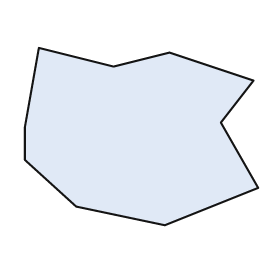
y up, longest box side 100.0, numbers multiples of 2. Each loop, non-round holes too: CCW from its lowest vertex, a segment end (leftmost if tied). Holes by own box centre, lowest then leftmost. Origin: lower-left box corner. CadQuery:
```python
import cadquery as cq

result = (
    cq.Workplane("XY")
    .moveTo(60.0, 0.0)
    .lineTo(100.0, 16.0)
    .lineTo(84.0, 44.0)
    .lineTo(98.0, 62.0)
    .lineTo(62.0, 74.0)
    .lineTo(38.0, 68.0)
    .lineTo(6.0, 76.0)
    .lineTo(0.0, 42.0)
    .lineTo(0.0, 28.0)
    .lineTo(22.0, 8.0)
    .close()
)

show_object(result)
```